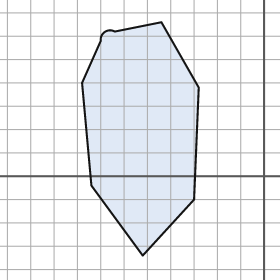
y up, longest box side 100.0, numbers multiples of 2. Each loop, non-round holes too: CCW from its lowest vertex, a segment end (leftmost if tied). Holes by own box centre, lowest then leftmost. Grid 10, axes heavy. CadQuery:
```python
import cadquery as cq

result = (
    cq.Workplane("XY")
    .moveTo(-52.0, -34.0)
    .lineTo(-30.0, -10.0)
    .lineTo(-28.0, 38.0)
    .lineTo(-44.0, 66.0)
    .lineTo(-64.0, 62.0)
    .threePointArc((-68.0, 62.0), (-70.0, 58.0))
    .lineTo(-78.0, 40.0)
    .lineTo(-74.0, -4.0)
    .close()
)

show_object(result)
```